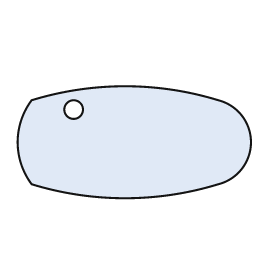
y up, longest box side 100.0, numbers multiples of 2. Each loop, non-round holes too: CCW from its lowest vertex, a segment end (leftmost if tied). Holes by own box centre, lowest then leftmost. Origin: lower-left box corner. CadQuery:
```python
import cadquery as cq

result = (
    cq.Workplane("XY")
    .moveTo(6.0, 6.0)
    .threePointArc((46.0, 0.0), (86.0, 6.0))
    .threePointArc((100.0, 24.0), (86.0, 42.0))
    .threePointArc((46.0, 48.0), (6.0, 42.0))
    .threePointArc((0.0, 24.0), (6.0, 6.0))
    .close()
    .moveTo(24.0, 38.0)
    .circle(4.0)
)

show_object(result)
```